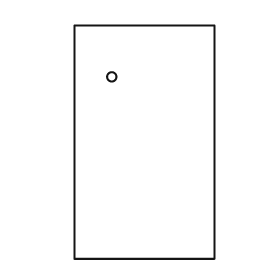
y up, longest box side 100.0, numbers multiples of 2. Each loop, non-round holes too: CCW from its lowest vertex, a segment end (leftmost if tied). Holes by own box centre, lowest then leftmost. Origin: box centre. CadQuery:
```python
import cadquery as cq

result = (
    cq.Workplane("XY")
    .moveTo(-30.0, -50.0)
    .lineTo(30.0, -50.0)
    .lineTo(30.0, 50.0)
    .lineTo(-30.0, 50.0)
    .close()
    .moveTo(-14.0, 28.0)
    .circle(2.0)
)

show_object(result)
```